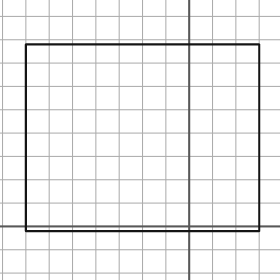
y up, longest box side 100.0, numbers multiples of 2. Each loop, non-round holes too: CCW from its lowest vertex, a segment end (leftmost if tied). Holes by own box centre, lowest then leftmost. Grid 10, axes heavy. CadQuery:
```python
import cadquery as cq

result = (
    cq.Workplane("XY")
    .moveTo(-70.0, -2.0)
    .lineTo(30.0, -2.0)
    .lineTo(30.0, 78.0)
    .lineTo(-70.0, 78.0)
    .close()
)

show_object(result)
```